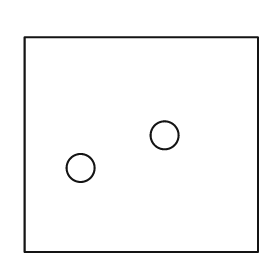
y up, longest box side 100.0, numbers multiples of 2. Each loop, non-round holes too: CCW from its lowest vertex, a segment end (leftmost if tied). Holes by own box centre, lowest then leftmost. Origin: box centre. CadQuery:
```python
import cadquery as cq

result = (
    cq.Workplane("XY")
    .moveTo(-50.0, -46.0)
    .lineTo(50.0, -46.0)
    .lineTo(50.0, 46.0)
    .lineTo(-50.0, 46.0)
    .close()
    .moveTo(-26.0, -10.0)
    .circle(6.0)
    .moveTo(10.0, 4.0)
    .circle(6.0)
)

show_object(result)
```